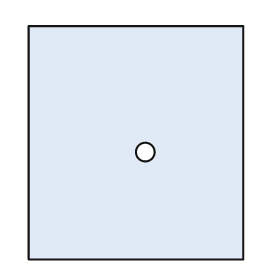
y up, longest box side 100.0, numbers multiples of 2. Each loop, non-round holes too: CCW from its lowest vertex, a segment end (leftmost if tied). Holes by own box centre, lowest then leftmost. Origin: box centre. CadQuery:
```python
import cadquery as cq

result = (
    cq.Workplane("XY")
    .moveTo(-46.0, -50.0)
    .lineTo(46.0, -50.0)
    .lineTo(46.0, 50.0)
    .lineTo(-46.0, 50.0)
    .close()
    .moveTo(4.0, -4.0)
    .circle(4.0)
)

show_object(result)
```